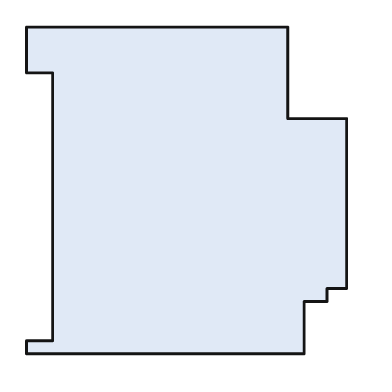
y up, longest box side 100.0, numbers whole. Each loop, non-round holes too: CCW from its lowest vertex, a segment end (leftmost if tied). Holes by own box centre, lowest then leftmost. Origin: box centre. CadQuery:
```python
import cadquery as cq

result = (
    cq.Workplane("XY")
    .moveTo(-49.0, -50.0)
    .lineTo(36.0, -50.0)
    .lineTo(36.0, -34.0)
    .lineTo(43.0, -34.0)
    .lineTo(43.0, -30.0)
    .lineTo(49.0, -30.0)
    .lineTo(49.0, 22.0)
    .lineTo(31.0, 22.0)
    .lineTo(31.0, 50.0)
    .lineTo(-49.0, 50.0)
    .lineTo(-49.0, 36.0)
    .lineTo(-41.0, 36.0)
    .lineTo(-41.0, -46.0)
    .lineTo(-49.0, -46.0)
    .close()
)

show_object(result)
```